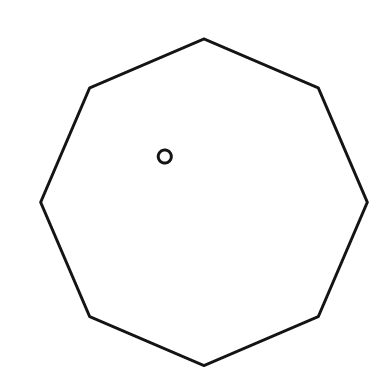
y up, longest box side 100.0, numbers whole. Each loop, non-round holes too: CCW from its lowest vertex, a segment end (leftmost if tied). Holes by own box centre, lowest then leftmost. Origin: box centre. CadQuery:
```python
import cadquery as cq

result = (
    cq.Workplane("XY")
    .moveTo(0.0, -50.0)
    .lineTo(35.0, -35.0)
    .lineTo(50.0, 0.0)
    .lineTo(35.0, 35.0)
    .lineTo(0.0, 50.0)
    .lineTo(-35.0, 35.0)
    .lineTo(-50.0, 0.0)
    .lineTo(-35.0, -35.0)
    .close()
    .moveTo(-12.0, 14.0)
    .circle(2.0)
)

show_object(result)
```